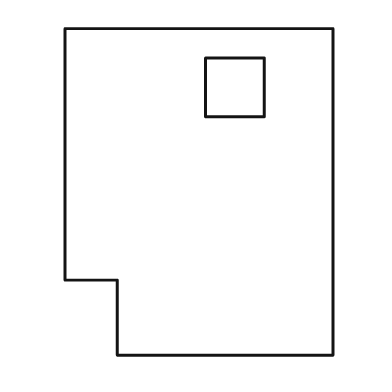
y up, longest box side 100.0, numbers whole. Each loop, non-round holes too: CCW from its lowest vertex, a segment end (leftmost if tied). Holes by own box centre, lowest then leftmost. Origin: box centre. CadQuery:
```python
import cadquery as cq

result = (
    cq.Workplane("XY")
    .moveTo(-25.0, -50.0)
    .lineTo(41.0, -50.0)
    .lineTo(41.0, 50.0)
    .lineTo(-41.0, 50.0)
    .lineTo(-41.0, -27.0)
    .lineTo(-25.0, -27.0)
    .close()
    .moveTo(2.0, 23.0)
    .lineTo(20.0, 23.0)
    .lineTo(20.0, 41.0)
    .lineTo(2.0, 41.0)
    .close()
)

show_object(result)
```